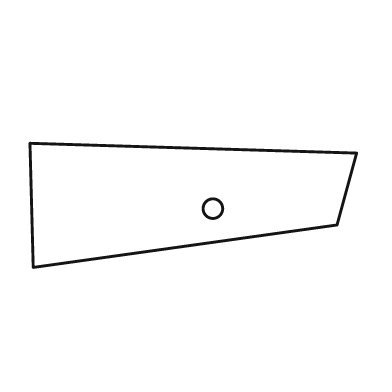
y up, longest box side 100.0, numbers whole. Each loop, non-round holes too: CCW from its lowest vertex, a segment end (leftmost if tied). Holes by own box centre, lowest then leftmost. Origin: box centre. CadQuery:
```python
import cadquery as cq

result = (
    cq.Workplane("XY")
    .moveTo(-49.0, -19.0)
    .lineTo(44.0, -6.0)
    .lineTo(50.0, 16.0)
    .lineTo(-50.0, 19.0)
    .close()
    .moveTo(6.0, -1.0)
    .circle(3.0)
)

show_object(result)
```